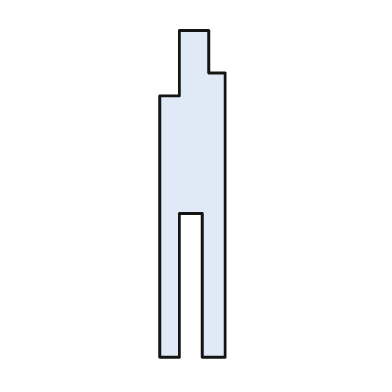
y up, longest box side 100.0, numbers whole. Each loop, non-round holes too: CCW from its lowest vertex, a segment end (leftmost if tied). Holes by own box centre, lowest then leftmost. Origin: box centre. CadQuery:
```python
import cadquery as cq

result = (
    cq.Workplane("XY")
    .moveTo(-10.0, -50.0)
    .lineTo(-4.0, -50.0)
    .lineTo(-4.0, -6.0)
    .lineTo(3.0, -6.0)
    .lineTo(3.0, -50.0)
    .lineTo(10.0, -50.0)
    .lineTo(10.0, 37.0)
    .lineTo(5.0, 37.0)
    .lineTo(5.0, 50.0)
    .lineTo(-4.0, 50.0)
    .lineTo(-4.0, 30.0)
    .lineTo(-10.0, 30.0)
    .close()
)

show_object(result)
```